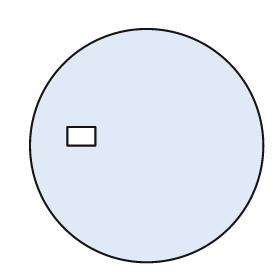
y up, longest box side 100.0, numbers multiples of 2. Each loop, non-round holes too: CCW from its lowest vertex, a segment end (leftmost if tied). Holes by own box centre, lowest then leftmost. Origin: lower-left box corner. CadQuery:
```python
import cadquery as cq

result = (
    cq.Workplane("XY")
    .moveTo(50.0, 50.0)
    .circle(50.0)
    .moveTo(16.0, 50.0)
    .lineTo(28.0, 50.0)
    .lineTo(28.0, 58.0)
    .lineTo(16.0, 58.0)
    .close()
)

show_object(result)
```